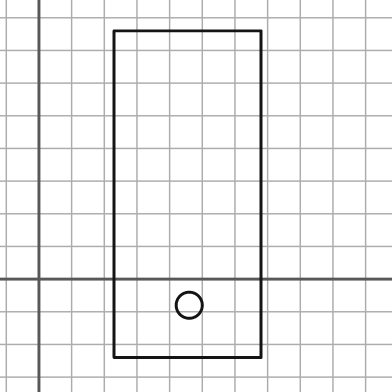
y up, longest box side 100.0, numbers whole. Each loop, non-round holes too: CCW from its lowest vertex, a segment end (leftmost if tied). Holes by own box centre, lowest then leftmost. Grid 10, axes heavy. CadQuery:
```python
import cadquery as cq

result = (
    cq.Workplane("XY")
    .moveTo(23.0, -24.0)
    .lineTo(68.0, -24.0)
    .lineTo(68.0, 76.0)
    .lineTo(23.0, 76.0)
    .close()
    .moveTo(46.0, -8.0)
    .circle(4.0)
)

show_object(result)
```